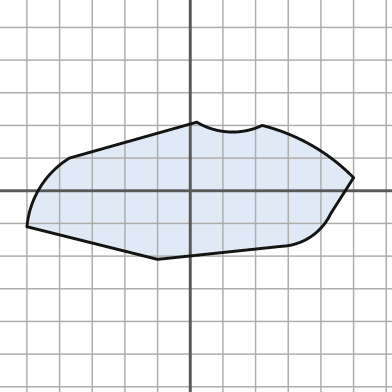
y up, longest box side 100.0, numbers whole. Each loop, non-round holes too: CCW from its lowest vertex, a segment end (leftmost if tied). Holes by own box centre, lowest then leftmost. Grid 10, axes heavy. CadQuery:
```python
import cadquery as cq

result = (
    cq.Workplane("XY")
    .moveTo(-10.0, -21.0)
    .lineTo(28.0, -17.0)
    .threePointArc((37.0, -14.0), (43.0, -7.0))
    .lineTo(50.0, 4.0)
    .threePointArc((37.0, 14.0), (22.0, 20.0))
    .threePointArc((12.0, 18.0), (2.0, 21.0))
    .lineTo(-37.0, 10.0)
    .threePointArc((-46.0, 1.0), (-50.0, -11.0))
    .close()
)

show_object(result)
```